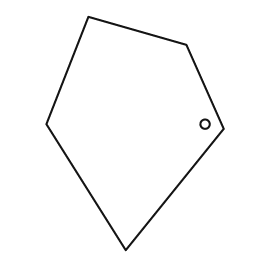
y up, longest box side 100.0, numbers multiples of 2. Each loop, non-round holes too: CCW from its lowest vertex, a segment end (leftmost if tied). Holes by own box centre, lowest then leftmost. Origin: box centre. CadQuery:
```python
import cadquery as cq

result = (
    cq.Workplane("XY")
    .moveTo(-4.0, -50.0)
    .lineTo(38.0, 2.0)
    .lineTo(22.0, 38.0)
    .lineTo(-20.0, 50.0)
    .lineTo(-38.0, 4.0)
    .close()
    .moveTo(30.0, 4.0)
    .circle(2.0)
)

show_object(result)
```